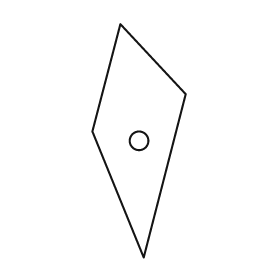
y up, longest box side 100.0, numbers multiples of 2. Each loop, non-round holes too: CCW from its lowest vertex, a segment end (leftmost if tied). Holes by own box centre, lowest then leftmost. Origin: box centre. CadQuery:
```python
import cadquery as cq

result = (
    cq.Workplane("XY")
    .moveTo(2.0, -50.0)
    .lineTo(20.0, 20.0)
    .lineTo(-8.0, 50.0)
    .lineTo(-20.0, 4.0)
    .close()
    .moveTo(0.0, 0.0)
    .circle(4.0)
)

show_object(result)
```